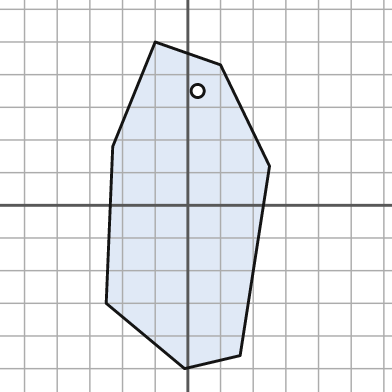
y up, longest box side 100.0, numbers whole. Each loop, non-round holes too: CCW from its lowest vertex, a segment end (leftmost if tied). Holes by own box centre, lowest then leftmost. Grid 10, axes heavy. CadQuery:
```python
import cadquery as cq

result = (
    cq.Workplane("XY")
    .moveTo(-1.0, -50.0)
    .lineTo(16.0, -46.0)
    .lineTo(25.0, 12.0)
    .lineTo(10.0, 43.0)
    .lineTo(-10.0, 50.0)
    .lineTo(-23.0, 18.0)
    .lineTo(-25.0, -30.0)
    .close()
    .moveTo(3.0, 35.0)
    .circle(2.0)
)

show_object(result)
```